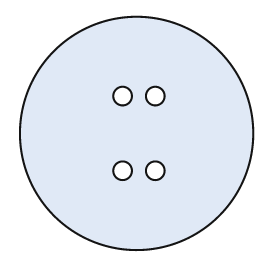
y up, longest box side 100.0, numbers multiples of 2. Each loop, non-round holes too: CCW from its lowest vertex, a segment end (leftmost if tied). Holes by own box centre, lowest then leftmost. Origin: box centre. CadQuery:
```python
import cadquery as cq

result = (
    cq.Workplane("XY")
    .moveTo(0.0, 0.0)
    .circle(50.0)
    .moveTo(-6.0, -16.0)
    .circle(4.0)
    .moveTo(8.0, -16.0)
    .circle(4.0)
    .moveTo(-6.0, 16.0)
    .circle(4.0)
    .moveTo(8.0, 16.0)
    .circle(4.0)
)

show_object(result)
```